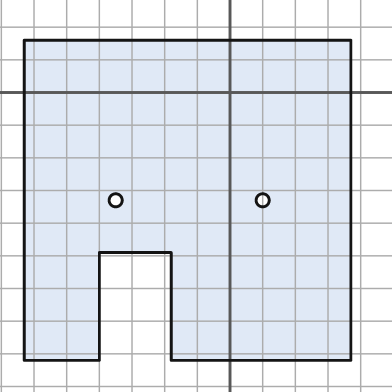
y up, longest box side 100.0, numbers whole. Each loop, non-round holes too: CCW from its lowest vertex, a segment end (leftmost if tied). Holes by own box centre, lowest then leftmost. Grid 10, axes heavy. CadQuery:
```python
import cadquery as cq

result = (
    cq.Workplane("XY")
    .moveTo(-63.0, -82.0)
    .lineTo(-40.0, -82.0)
    .lineTo(-40.0, -49.0)
    .lineTo(-18.0, -49.0)
    .lineTo(-18.0, -82.0)
    .lineTo(37.0, -82.0)
    .lineTo(37.0, 16.0)
    .lineTo(-63.0, 16.0)
    .close()
    .moveTo(-35.0, -33.0)
    .circle(2.0)
    .moveTo(10.0, -33.0)
    .circle(2.0)
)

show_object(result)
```